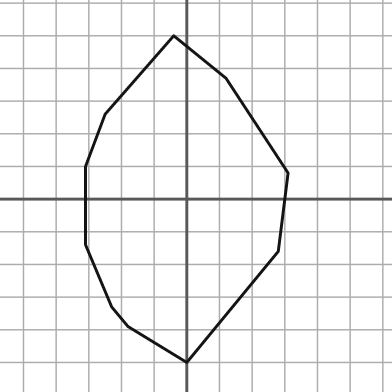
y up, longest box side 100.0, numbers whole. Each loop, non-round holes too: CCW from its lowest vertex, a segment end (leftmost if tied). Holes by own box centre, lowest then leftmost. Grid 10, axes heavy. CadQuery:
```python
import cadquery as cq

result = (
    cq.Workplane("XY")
    .moveTo(0.0, -50.0)
    .lineTo(28.0, -16.0)
    .lineTo(31.0, 8.0)
    .lineTo(12.0, 37.0)
    .lineTo(-4.0, 50.0)
    .lineTo(-25.0, 26.0)
    .lineTo(-31.0, 10.0)
    .lineTo(-31.0, -14.0)
    .lineTo(-23.0, -33.0)
    .lineTo(-18.0, -39.0)
    .close()
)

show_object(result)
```